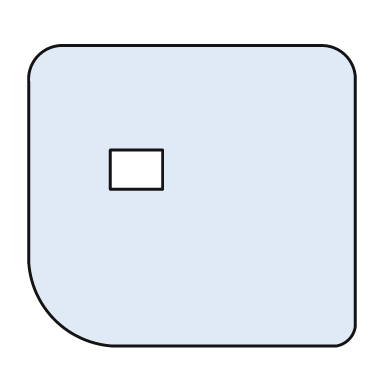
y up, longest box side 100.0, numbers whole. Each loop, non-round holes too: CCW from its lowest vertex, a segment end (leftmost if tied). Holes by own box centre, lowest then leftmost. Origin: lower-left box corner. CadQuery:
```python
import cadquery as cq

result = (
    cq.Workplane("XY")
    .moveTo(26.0, 0.0)
    .lineTo(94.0, 0.0)
    .threePointArc((98.0, 2.0), (100.0, 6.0))
    .lineTo(100.0, 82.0)
    .threePointArc((97.0, 89.0), (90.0, 92.0))
    .lineTo(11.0, 92.0)
    .threePointArc((3.0, 89.0), (0.0, 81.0))
    .lineTo(0.0, 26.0)
    .threePointArc((8.0, 8.0), (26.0, 0.0))
    .close()
    .moveTo(25.0, 48.0)
    .lineTo(41.0, 48.0)
    .lineTo(41.0, 60.0)
    .lineTo(25.0, 60.0)
    .close()
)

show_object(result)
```